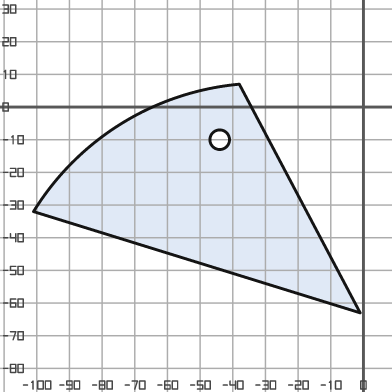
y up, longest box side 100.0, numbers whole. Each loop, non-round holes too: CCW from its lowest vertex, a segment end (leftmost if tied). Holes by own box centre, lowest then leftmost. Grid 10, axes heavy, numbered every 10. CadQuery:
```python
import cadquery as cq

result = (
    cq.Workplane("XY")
    .moveTo(-1.0, -63.0)
    .lineTo(-38.0, 7.0)
    .threePointArc((-74.0, -5.0), (-101.0, -32.0))
    .close()
    .moveTo(-44.0, -10.0)
    .circle(3.0)
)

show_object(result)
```